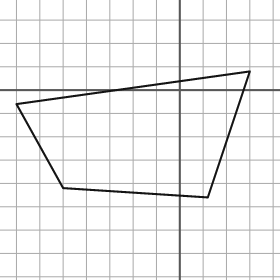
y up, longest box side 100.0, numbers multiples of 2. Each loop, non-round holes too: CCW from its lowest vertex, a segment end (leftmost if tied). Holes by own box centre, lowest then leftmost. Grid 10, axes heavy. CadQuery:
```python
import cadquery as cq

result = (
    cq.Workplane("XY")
    .moveTo(12.0, -46.0)
    .lineTo(30.0, 8.0)
    .lineTo(-70.0, -6.0)
    .lineTo(-50.0, -42.0)
    .close()
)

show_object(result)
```